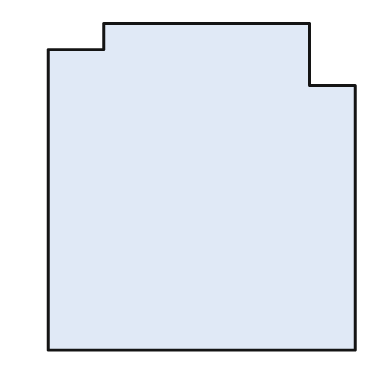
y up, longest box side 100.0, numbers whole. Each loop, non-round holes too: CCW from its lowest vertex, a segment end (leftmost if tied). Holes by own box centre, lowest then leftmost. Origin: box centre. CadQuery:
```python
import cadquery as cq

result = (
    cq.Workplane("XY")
    .moveTo(-47.0, -50.0)
    .lineTo(47.0, -50.0)
    .lineTo(47.0, 31.0)
    .lineTo(33.0, 31.0)
    .lineTo(33.0, 50.0)
    .lineTo(-30.0, 50.0)
    .lineTo(-30.0, 42.0)
    .lineTo(-47.0, 42.0)
    .close()
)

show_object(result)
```